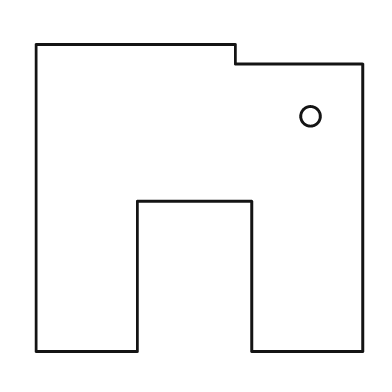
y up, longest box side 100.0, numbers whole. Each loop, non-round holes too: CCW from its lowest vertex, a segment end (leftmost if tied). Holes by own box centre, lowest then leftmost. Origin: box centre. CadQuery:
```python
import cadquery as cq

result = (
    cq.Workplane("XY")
    .moveTo(-50.0, -47.0)
    .lineTo(-19.0, -47.0)
    .lineTo(-19.0, -1.0)
    .lineTo(16.0, -1.0)
    .lineTo(16.0, -47.0)
    .lineTo(50.0, -47.0)
    .lineTo(50.0, 41.0)
    .lineTo(11.0, 41.0)
    .lineTo(11.0, 47.0)
    .lineTo(-50.0, 47.0)
    .close()
    .moveTo(34.0, 25.0)
    .circle(3.0)
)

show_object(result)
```